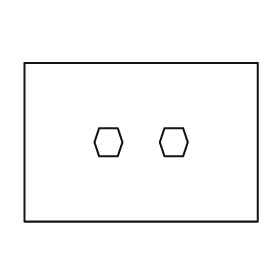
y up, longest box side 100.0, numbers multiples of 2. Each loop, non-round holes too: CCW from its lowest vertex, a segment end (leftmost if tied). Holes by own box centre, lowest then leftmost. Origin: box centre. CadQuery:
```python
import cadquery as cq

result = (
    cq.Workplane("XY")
    .moveTo(-50.0, -34.0)
    .lineTo(50.0, -34.0)
    .lineTo(50.0, 34.0)
    .lineTo(-50.0, 34.0)
    .close()
    .moveTo(-18.0, -6.0)
    .lineTo(-10.0, -6.0)
    .lineTo(-8.0, 0.0)
    .lineTo(-10.0, 6.0)
    .lineTo(-18.0, 6.0)
    .lineTo(-20.0, 0.0)
    .close()
    .moveTo(10.0, -6.0)
    .lineTo(18.0, -6.0)
    .lineTo(20.0, 0.0)
    .lineTo(18.0, 6.0)
    .lineTo(10.0, 6.0)
    .lineTo(8.0, 0.0)
    .close()
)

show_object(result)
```